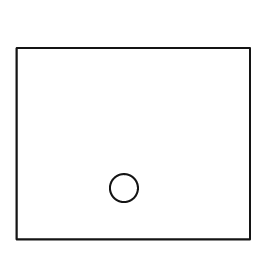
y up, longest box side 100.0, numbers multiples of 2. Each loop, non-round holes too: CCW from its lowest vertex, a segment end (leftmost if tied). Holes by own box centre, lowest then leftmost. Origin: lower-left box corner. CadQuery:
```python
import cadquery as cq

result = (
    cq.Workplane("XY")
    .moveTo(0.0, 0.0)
    .lineTo(100.0, 0.0)
    .lineTo(100.0, 82.0)
    .lineTo(0.0, 82.0)
    .close()
    .moveTo(46.0, 22.0)
    .circle(6.0)
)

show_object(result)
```